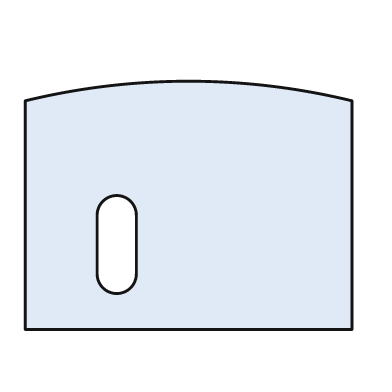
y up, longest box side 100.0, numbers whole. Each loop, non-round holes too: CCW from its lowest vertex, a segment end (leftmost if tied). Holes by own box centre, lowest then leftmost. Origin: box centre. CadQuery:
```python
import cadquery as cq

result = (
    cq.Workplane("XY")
    .moveTo(-50.0, -38.0)
    .lineTo(50.0, -38.0)
    .lineTo(50.0, 32.0)
    .threePointArc((0.0, 38.0), (-50.0, 32.0))
    .close()
    .moveTo(-28.0, -21.0)
    .threePointArc((-22.0, -27.0), (-16.0, -21.0))
    .lineTo(-16.0, -3.0)
    .threePointArc((-22.0, 3.0), (-28.0, -3.0))
    .close()
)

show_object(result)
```